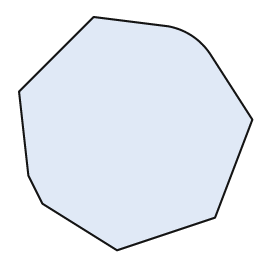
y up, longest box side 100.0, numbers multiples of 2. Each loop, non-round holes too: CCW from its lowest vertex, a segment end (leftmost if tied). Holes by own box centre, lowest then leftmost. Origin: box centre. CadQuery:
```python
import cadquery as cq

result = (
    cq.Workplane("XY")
    .moveTo(-8.0, -50.0)
    .lineTo(34.0, -36.0)
    .lineTo(50.0, 6.0)
    .lineTo(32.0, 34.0)
    .threePointArc((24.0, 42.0), (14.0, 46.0))
    .lineTo(-18.0, 50.0)
    .lineTo(-50.0, 18.0)
    .lineTo(-46.0, -18.0)
    .lineTo(-40.0, -30.0)
    .close()
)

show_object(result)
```